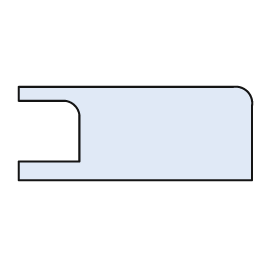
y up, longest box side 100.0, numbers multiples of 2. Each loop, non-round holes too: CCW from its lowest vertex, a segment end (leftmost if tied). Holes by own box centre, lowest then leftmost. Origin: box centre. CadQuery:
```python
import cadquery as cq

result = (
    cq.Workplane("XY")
    .moveTo(-50.0, -20.0)
    .lineTo(50.0, -20.0)
    .lineTo(50.0, 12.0)
    .threePointArc((48.0, 18.0), (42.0, 20.0))
    .lineTo(-50.0, 20.0)
    .lineTo(-50.0, 14.0)
    .lineTo(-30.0, 14.0)
    .threePointArc((-26.0, 12.0), (-24.0, 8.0))
    .lineTo(-24.0, -12.0)
    .lineTo(-50.0, -12.0)
    .close()
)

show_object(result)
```